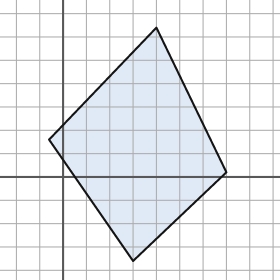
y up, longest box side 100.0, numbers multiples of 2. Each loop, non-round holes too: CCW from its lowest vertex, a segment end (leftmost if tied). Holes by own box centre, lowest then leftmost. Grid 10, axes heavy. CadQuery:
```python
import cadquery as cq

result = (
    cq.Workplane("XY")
    .moveTo(30.0, -36.0)
    .lineTo(70.0, 2.0)
    .lineTo(40.0, 64.0)
    .lineTo(-6.0, 16.0)
    .close()
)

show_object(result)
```